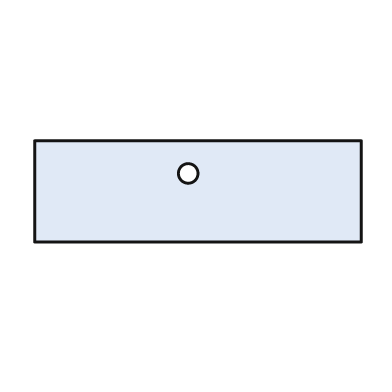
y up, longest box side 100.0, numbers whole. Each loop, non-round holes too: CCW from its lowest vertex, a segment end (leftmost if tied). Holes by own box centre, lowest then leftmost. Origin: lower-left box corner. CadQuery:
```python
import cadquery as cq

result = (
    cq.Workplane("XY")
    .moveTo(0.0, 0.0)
    .lineTo(100.0, 0.0)
    .lineTo(100.0, 31.0)
    .lineTo(0.0, 31.0)
    .close()
    .moveTo(47.0, 21.0)
    .circle(3.0)
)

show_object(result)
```